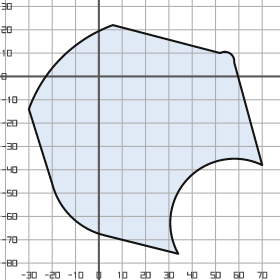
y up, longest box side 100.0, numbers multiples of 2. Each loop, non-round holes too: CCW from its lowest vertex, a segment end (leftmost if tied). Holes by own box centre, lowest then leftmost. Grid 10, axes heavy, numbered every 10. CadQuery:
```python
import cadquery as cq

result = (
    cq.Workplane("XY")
    .moveTo(34.0, -76.0)
    .threePointArc((38.0, -44.0), (70.0, -38.0))
    .lineTo(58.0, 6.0)
    .threePointArc((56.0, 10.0), (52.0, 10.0))
    .lineTo(6.0, 22.0)
    .threePointArc((-16.0, 8.0), (-30.0, -14.0))
    .lineTo(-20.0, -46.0)
    .threePointArc((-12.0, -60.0), (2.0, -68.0))
    .close()
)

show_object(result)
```